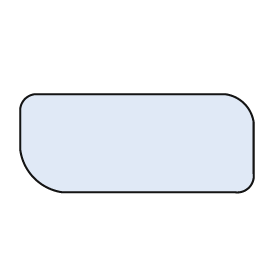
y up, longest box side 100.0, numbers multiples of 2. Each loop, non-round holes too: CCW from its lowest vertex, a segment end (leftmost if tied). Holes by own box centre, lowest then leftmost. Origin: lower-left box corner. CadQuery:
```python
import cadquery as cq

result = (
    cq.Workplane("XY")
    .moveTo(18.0, 0.0)
    .lineTo(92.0, 0.0)
    .threePointArc((98.0, 2.0), (100.0, 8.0))
    .lineTo(100.0, 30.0)
    .threePointArc((96.0, 38.0), (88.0, 42.0))
    .lineTo(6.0, 42.0)
    .threePointArc((2.0, 40.0), (0.0, 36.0))
    .lineTo(0.0, 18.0)
    .threePointArc((6.0, 6.0), (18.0, 0.0))
    .close()
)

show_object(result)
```